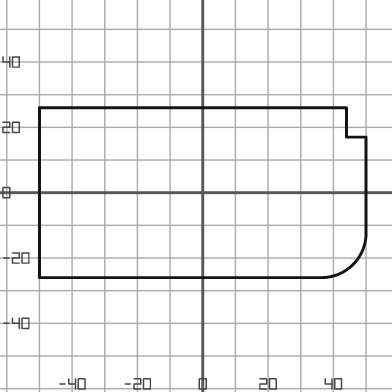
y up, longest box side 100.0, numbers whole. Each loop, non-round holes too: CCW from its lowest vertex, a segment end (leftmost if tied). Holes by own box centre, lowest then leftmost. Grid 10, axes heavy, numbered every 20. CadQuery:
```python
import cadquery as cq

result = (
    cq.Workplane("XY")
    .moveTo(-50.0, -26.0)
    .lineTo(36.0, -26.0)
    .threePointArc((46.0, -22.0), (50.0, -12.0))
    .lineTo(50.0, 17.0)
    .lineTo(44.0, 17.0)
    .lineTo(44.0, 26.0)
    .lineTo(-50.0, 26.0)
    .close()
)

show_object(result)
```